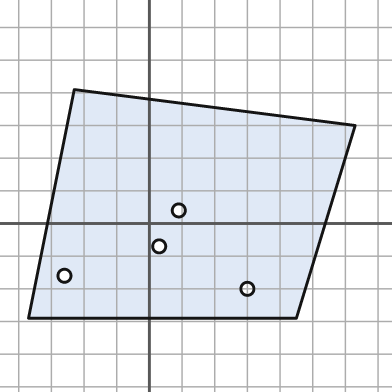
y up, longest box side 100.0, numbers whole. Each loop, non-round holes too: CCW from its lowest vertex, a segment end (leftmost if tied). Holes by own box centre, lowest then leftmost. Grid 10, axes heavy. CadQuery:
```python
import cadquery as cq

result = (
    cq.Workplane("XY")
    .moveTo(-37.0, -29.0)
    .lineTo(45.0, -29.0)
    .lineTo(63.0, 30.0)
    .lineTo(-23.0, 41.0)
    .close()
    .moveTo(30.0, -20.0)
    .circle(2.0)
    .moveTo(-26.0, -16.0)
    .circle(2.0)
    .moveTo(3.0, -7.0)
    .circle(2.0)
    .moveTo(9.0, 4.0)
    .circle(2.0)
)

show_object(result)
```